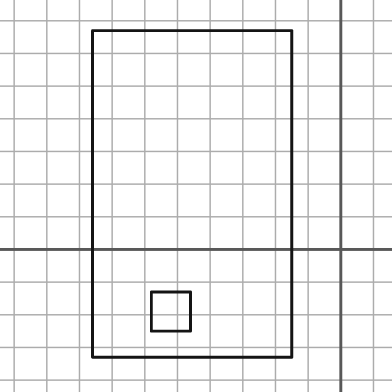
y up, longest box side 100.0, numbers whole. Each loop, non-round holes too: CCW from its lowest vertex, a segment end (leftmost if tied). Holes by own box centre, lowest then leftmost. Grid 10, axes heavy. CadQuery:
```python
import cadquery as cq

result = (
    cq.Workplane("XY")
    .moveTo(-76.0, -33.0)
    .lineTo(-15.0, -33.0)
    .lineTo(-15.0, 67.0)
    .lineTo(-76.0, 67.0)
    .close()
    .moveTo(-58.0, -25.0)
    .lineTo(-46.0, -25.0)
    .lineTo(-46.0, -13.0)
    .lineTo(-58.0, -13.0)
    .close()
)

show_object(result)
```